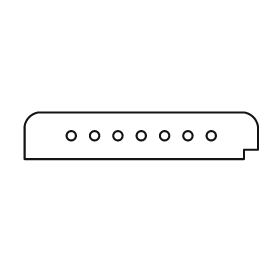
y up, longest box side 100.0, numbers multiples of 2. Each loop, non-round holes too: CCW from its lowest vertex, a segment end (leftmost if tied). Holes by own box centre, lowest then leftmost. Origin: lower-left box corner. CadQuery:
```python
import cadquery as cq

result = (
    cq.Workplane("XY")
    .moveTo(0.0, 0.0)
    .lineTo(94.0, 0.0)
    .lineTo(94.0, 4.0)
    .lineTo(100.0, 4.0)
    .lineTo(100.0, 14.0)
    .threePointArc((98.0, 18.0), (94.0, 20.0))
    .lineTo(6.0, 20.0)
    .threePointArc((2.0, 18.0), (0.0, 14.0))
    .close()
    .moveTo(20.0, 10.0)
    .circle(2.0)
    .moveTo(30.0, 10.0)
    .circle(2.0)
    .moveTo(40.0, 10.0)
    .circle(2.0)
    .moveTo(50.0, 10.0)
    .circle(2.0)
    .moveTo(60.0, 10.0)
    .circle(2.0)
    .moveTo(70.0, 10.0)
    .circle(2.0)
    .moveTo(80.0, 10.0)
    .circle(2.0)
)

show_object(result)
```